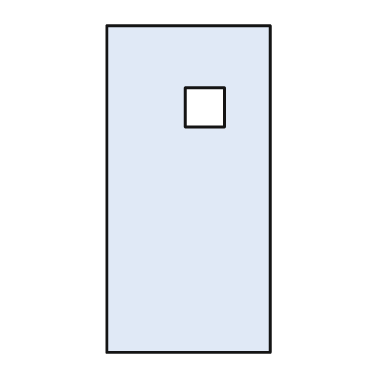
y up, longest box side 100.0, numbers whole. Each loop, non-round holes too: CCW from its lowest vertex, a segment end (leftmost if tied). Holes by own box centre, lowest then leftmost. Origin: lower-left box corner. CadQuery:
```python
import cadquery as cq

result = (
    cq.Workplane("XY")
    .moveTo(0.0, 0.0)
    .lineTo(50.0, 0.0)
    .lineTo(50.0, 100.0)
    .lineTo(0.0, 100.0)
    .close()
    .moveTo(24.0, 69.0)
    .lineTo(36.0, 69.0)
    .lineTo(36.0, 81.0)
    .lineTo(24.0, 81.0)
    .close()
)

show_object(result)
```